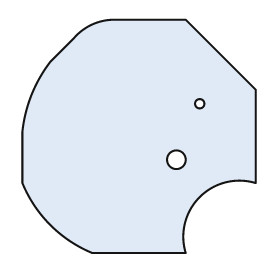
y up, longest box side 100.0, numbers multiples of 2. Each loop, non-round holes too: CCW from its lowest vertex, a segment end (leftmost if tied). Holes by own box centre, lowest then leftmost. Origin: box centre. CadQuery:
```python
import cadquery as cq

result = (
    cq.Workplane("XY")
    .moveTo(-20.0, -50.0)
    .lineTo(20.0, -50.0)
    .threePointArc((26.0, -26.0), (50.0, -20.0))
    .lineTo(50.0, 20.0)
    .lineTo(20.0, 50.0)
    .lineTo(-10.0, 50.0)
    .threePointArc((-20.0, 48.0), (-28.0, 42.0))
    .lineTo(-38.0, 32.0)
    .threePointArc((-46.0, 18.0), (-50.0, 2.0))
    .lineTo(-50.0, -20.0)
    .threePointArc((-38.0, -38.0), (-20.0, -50.0))
    .close()
    .moveTo(16.0, -10.0)
    .circle(4.0)
    .moveTo(26.0, 14.0)
    .circle(2.0)
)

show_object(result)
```